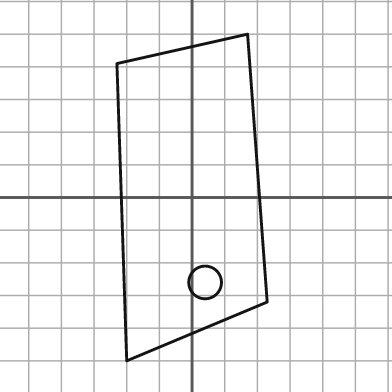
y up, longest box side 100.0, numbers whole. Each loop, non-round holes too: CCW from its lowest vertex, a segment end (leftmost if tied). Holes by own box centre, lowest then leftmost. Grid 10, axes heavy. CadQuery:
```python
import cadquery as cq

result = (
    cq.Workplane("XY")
    .moveTo(-20.0, -50.0)
    .lineTo(23.0, -32.0)
    .lineTo(17.0, 50.0)
    .lineTo(-23.0, 41.0)
    .close()
    .moveTo(4.0, -26.0)
    .circle(5.0)
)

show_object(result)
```